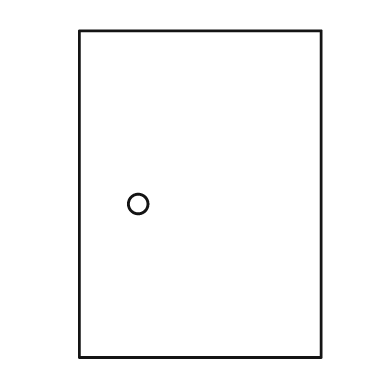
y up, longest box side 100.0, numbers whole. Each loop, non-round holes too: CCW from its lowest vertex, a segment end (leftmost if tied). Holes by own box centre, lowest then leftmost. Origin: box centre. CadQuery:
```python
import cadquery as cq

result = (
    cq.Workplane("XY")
    .moveTo(-37.0, -50.0)
    .lineTo(37.0, -50.0)
    .lineTo(37.0, 50.0)
    .lineTo(-37.0, 50.0)
    .close()
    .moveTo(-19.0, -3.0)
    .circle(3.0)
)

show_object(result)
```